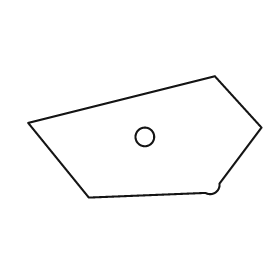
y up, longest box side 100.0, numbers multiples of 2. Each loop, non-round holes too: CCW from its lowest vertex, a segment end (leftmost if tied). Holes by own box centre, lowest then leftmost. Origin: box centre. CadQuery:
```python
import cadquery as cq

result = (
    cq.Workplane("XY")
    .moveTo(-24.0, -26.0)
    .lineTo(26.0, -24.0)
    .threePointArc((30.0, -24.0), (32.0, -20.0))
    .lineTo(50.0, 4.0)
    .lineTo(30.0, 26.0)
    .lineTo(-50.0, 6.0)
    .close()
    .moveTo(0.0, 0.0)
    .circle(4.0)
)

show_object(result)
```